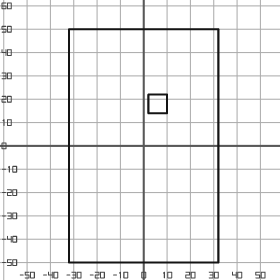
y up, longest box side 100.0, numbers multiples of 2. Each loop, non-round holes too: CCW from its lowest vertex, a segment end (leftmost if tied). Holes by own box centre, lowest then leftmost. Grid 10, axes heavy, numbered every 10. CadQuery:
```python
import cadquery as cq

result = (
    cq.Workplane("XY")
    .moveTo(-32.0, -50.0)
    .lineTo(32.0, -50.0)
    .lineTo(32.0, 50.0)
    .lineTo(-32.0, 50.0)
    .close()
    .moveTo(2.0, 14.0)
    .lineTo(10.0, 14.0)
    .lineTo(10.0, 22.0)
    .lineTo(2.0, 22.0)
    .close()
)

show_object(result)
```